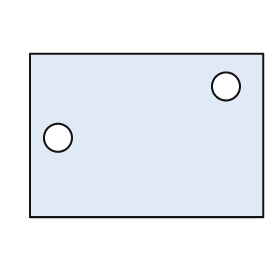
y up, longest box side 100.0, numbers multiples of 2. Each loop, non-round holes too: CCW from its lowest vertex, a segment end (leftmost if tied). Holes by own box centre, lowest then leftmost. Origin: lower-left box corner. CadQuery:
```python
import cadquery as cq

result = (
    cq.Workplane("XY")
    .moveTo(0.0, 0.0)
    .lineTo(100.0, 0.0)
    .lineTo(100.0, 70.0)
    .lineTo(0.0, 70.0)
    .close()
    .moveTo(12.0, 34.0)
    .circle(6.0)
    .moveTo(84.0, 56.0)
    .circle(6.0)
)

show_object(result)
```